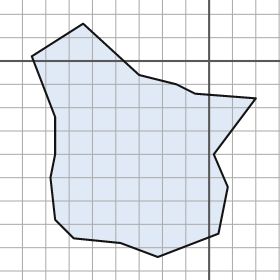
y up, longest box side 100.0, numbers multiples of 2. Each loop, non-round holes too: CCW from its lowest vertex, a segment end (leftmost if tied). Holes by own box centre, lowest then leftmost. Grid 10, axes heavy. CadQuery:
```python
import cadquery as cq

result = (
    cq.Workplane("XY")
    .moveTo(-22.0, -84.0)
    .lineTo(4.0, -74.0)
    .lineTo(8.0, -54.0)
    .lineTo(2.0, -40.0)
    .lineTo(20.0, -16.0)
    .lineTo(-6.0, -14.0)
    .lineTo(-14.0, -10.0)
    .lineTo(-30.0, -6.0)
    .lineTo(-54.0, 16.0)
    .lineTo(-76.0, 2.0)
    .lineTo(-66.0, -24.0)
    .lineTo(-66.0, -40.0)
    .lineTo(-68.0, -50.0)
    .lineTo(-66.0, -68.0)
    .lineTo(-58.0, -76.0)
    .lineTo(-38.0, -78.0)
    .close()
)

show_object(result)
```